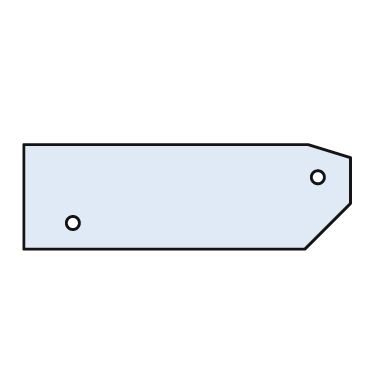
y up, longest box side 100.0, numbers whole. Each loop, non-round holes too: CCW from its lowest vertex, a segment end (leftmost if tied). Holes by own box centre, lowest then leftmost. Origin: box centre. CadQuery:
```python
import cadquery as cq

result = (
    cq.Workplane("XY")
    .moveTo(-50.0, -16.0)
    .lineTo(36.0, -16.0)
    .lineTo(50.0, -2.0)
    .lineTo(50.0, 12.0)
    .lineTo(37.0, 16.0)
    .lineTo(-50.0, 16.0)
    .close()
    .moveTo(-35.0, -8.0)
    .circle(2.0)
    .moveTo(40.0, 6.0)
    .circle(2.0)
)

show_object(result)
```